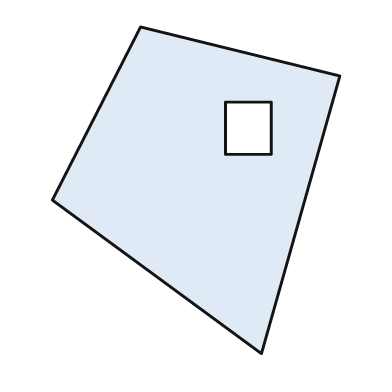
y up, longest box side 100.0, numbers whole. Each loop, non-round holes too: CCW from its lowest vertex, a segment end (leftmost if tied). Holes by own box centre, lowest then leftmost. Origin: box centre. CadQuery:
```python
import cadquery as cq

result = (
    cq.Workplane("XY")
    .moveTo(20.0, -50.0)
    .lineTo(44.0, 35.0)
    .lineTo(-17.0, 50.0)
    .lineTo(-44.0, -3.0)
    .close()
    .moveTo(9.0, 11.0)
    .lineTo(23.0, 11.0)
    .lineTo(23.0, 27.0)
    .lineTo(9.0, 27.0)
    .close()
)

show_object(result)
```